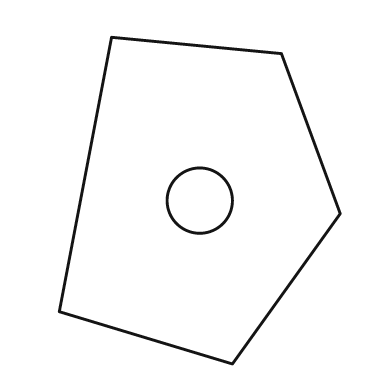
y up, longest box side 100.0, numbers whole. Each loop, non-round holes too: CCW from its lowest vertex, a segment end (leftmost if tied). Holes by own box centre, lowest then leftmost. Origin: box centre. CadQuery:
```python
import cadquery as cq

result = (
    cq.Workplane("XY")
    .moveTo(10.0, -50.0)
    .lineTo(43.0, -4.0)
    .lineTo(25.0, 45.0)
    .lineTo(-27.0, 50.0)
    .lineTo(-43.0, -34.0)
    .close()
    .moveTo(0.0, 0.0)
    .circle(10.0)
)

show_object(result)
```